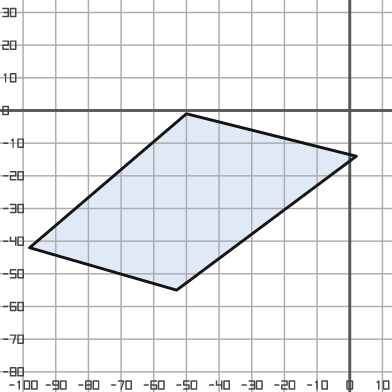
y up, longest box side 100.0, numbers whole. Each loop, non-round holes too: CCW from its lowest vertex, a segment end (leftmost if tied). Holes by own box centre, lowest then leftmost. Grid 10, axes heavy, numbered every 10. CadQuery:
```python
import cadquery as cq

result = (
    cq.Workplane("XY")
    .moveTo(-53.0, -55.0)
    .lineTo(2.0, -14.0)
    .lineTo(-50.0, -1.0)
    .lineTo(-98.0, -42.0)
    .close()
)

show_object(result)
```